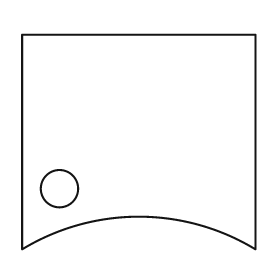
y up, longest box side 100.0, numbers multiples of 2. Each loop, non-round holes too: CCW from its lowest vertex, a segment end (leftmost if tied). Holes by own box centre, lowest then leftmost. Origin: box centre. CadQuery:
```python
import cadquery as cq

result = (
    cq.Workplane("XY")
    .moveTo(-50.0, -46.0)
    .threePointArc((0.0, -32.0), (50.0, -46.0))
    .lineTo(50.0, 46.0)
    .lineTo(-50.0, 46.0)
    .close()
    .moveTo(-34.0, -20.0)
    .circle(8.0)
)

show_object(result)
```